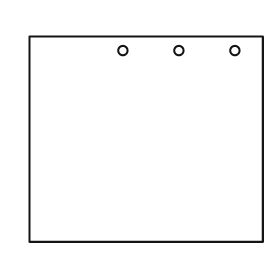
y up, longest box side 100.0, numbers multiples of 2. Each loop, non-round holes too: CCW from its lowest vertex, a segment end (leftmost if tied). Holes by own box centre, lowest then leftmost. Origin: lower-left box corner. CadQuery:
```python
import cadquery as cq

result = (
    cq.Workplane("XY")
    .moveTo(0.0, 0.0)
    .lineTo(100.0, 0.0)
    .lineTo(100.0, 88.0)
    .lineTo(0.0, 88.0)
    .close()
    .moveTo(40.0, 82.0)
    .circle(2.0)
    .moveTo(64.0, 82.0)
    .circle(2.0)
    .moveTo(88.0, 82.0)
    .circle(2.0)
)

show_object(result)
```